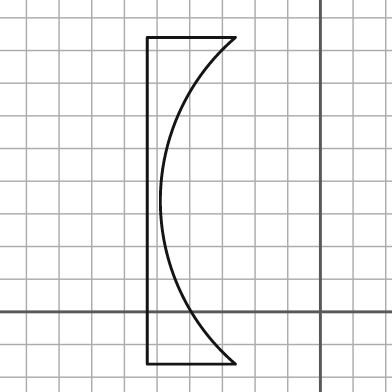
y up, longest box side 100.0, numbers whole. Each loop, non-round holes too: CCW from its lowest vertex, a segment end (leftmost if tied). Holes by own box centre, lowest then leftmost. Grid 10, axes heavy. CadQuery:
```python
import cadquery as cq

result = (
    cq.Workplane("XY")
    .moveTo(-53.0, -16.0)
    .lineTo(-26.0, -16.0)
    .threePointArc((-49.0, 34.0), (-26.0, 84.0))
    .lineTo(-53.0, 84.0)
    .close()
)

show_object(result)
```